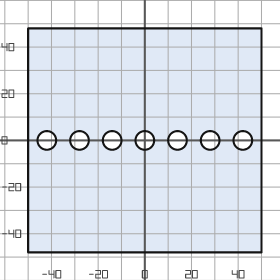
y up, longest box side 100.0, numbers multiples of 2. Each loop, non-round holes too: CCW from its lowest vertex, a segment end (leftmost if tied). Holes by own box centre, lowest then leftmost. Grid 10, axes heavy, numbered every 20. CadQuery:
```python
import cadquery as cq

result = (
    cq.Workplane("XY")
    .moveTo(-50.0, -48.0)
    .lineTo(50.0, -48.0)
    .lineTo(50.0, 48.0)
    .lineTo(-50.0, 48.0)
    .close()
    .moveTo(-42.0, 0.0)
    .circle(4.0)
    .moveTo(-28.0, 0.0)
    .circle(4.0)
    .moveTo(-14.0, 0.0)
    .circle(4.0)
    .moveTo(0.0, 0.0)
    .circle(4.0)
    .moveTo(14.0, 0.0)
    .circle(4.0)
    .moveTo(28.0, 0.0)
    .circle(4.0)
    .moveTo(42.0, 0.0)
    .circle(4.0)
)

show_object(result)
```